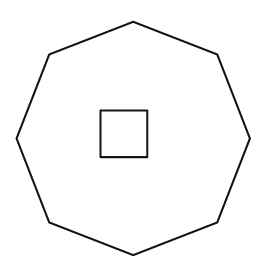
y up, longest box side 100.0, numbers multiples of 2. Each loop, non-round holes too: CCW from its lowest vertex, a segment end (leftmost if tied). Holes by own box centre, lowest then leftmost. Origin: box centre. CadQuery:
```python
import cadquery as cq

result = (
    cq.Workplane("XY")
    .moveTo(0.0, -50.0)
    .lineTo(36.0, -36.0)
    .lineTo(50.0, 0.0)
    .lineTo(36.0, 36.0)
    .lineTo(0.0, 50.0)
    .lineTo(-36.0, 36.0)
    .lineTo(-50.0, 0.0)
    .lineTo(-36.0, -36.0)
    .close()
    .moveTo(-14.0, -8.0)
    .lineTo(6.0, -8.0)
    .lineTo(6.0, 12.0)
    .lineTo(-14.0, 12.0)
    .close()
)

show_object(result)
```